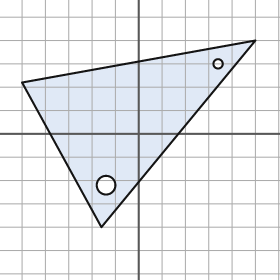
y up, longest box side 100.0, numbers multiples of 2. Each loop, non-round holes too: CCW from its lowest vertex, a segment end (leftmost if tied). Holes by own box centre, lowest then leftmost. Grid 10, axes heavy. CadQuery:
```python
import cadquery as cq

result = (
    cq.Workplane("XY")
    .moveTo(-16.0, -40.0)
    .lineTo(50.0, 40.0)
    .lineTo(-50.0, 22.0)
    .close()
    .moveTo(-14.0, -22.0)
    .circle(4.0)
    .moveTo(34.0, 30.0)
    .circle(2.0)
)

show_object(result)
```